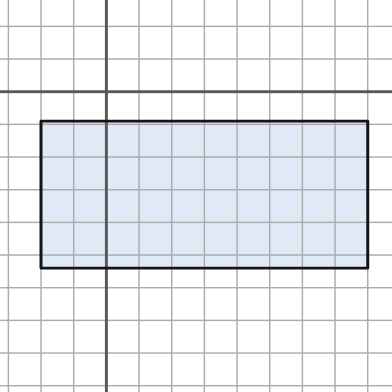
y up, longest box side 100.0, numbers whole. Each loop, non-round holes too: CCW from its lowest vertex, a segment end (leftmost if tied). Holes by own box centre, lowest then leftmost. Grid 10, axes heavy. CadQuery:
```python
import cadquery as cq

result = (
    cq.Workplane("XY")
    .moveTo(-20.0, -54.0)
    .lineTo(80.0, -54.0)
    .lineTo(80.0, -9.0)
    .lineTo(-20.0, -9.0)
    .close()
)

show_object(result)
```